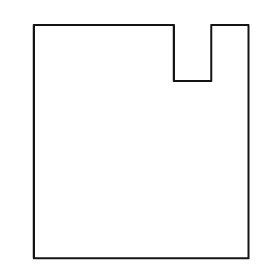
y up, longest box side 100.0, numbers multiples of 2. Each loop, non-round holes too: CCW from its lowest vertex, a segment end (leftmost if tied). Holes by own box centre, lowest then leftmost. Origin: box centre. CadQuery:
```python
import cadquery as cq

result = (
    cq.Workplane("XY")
    .moveTo(-46.0, -50.0)
    .lineTo(46.0, -50.0)
    .lineTo(46.0, 50.0)
    .lineTo(30.0, 50.0)
    .lineTo(30.0, 26.0)
    .lineTo(14.0, 26.0)
    .lineTo(14.0, 50.0)
    .lineTo(-46.0, 50.0)
    .close()
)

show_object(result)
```